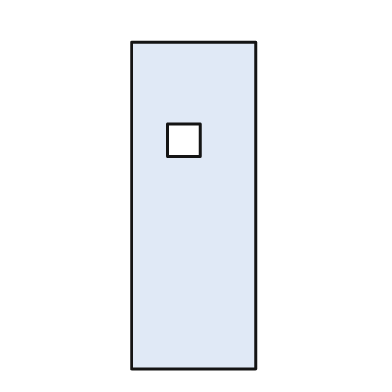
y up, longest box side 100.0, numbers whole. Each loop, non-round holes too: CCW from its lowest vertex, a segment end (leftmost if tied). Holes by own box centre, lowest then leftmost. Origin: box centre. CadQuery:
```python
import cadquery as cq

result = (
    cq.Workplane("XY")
    .moveTo(-19.0, -50.0)
    .lineTo(19.0, -50.0)
    .lineTo(19.0, 50.0)
    .lineTo(-19.0, 50.0)
    .close()
    .moveTo(-8.0, 15.0)
    .lineTo(2.0, 15.0)
    .lineTo(2.0, 25.0)
    .lineTo(-8.0, 25.0)
    .close()
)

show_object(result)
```